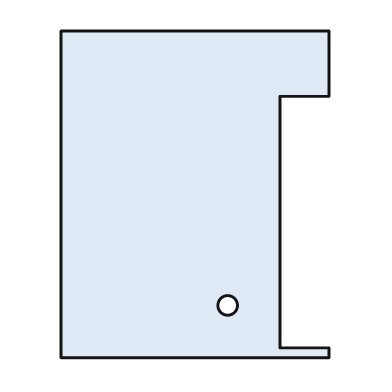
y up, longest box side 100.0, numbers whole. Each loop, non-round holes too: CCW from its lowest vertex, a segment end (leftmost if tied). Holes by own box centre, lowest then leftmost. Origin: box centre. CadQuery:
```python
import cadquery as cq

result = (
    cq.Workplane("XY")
    .moveTo(-41.0, -50.0)
    .lineTo(41.0, -50.0)
    .lineTo(41.0, -47.0)
    .lineTo(26.0, -47.0)
    .lineTo(26.0, 30.0)
    .lineTo(41.0, 30.0)
    .lineTo(41.0, 50.0)
    .lineTo(-41.0, 50.0)
    .close()
    .moveTo(10.0, -34.0)
    .circle(3.0)
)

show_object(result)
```